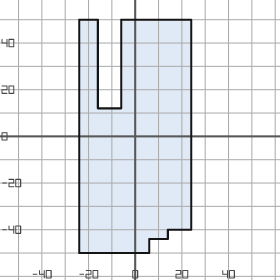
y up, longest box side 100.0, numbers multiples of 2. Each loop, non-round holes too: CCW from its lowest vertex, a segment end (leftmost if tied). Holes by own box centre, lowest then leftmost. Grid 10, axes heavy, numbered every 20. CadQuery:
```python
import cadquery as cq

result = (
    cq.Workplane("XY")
    .moveTo(-24.0, -50.0)
    .lineTo(6.0, -50.0)
    .lineTo(6.0, -44.0)
    .lineTo(14.0, -44.0)
    .lineTo(14.0, -40.0)
    .lineTo(24.0, -40.0)
    .lineTo(24.0, 50.0)
    .lineTo(-6.0, 50.0)
    .lineTo(-6.0, 12.0)
    .lineTo(-16.0, 12.0)
    .lineTo(-16.0, 50.0)
    .lineTo(-24.0, 50.0)
    .close()
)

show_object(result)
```